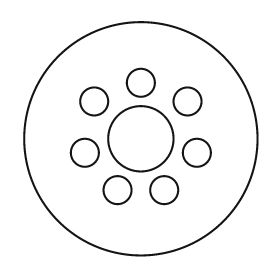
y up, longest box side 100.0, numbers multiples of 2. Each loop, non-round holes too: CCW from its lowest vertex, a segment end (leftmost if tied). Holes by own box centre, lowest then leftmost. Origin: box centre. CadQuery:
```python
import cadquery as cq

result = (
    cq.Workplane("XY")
    .moveTo(0.0, 0.0)
    .circle(50.0)
    .moveTo(-10.0, -22.0)
    .circle(6.0)
    .moveTo(10.0, -22.0)
    .circle(6.0)
    .moveTo(-24.0, -6.0)
    .circle(6.0)
    .moveTo(24.0, -6.0)
    .circle(6.0)
    .moveTo(0.0, 0.0)
    .circle(14.0)
    .moveTo(-20.0, 16.0)
    .circle(6.0)
    .moveTo(20.0, 16.0)
    .circle(6.0)
    .moveTo(0.0, 24.0)
    .circle(6.0)
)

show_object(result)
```